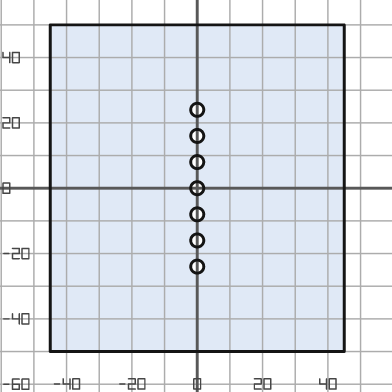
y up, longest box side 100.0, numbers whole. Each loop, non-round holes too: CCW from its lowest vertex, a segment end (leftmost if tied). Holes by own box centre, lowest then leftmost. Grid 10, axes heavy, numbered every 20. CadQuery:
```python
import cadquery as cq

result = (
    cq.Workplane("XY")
    .moveTo(-45.0, -50.0)
    .lineTo(45.0, -50.0)
    .lineTo(45.0, 50.0)
    .lineTo(-45.0, 50.0)
    .close()
    .moveTo(0.0, -24.0)
    .circle(2.0)
    .moveTo(0.0, -16.0)
    .circle(2.0)
    .moveTo(0.0, -8.0)
    .circle(2.0)
    .moveTo(0.0, 0.0)
    .circle(2.0)
    .moveTo(0.0, 8.0)
    .circle(2.0)
    .moveTo(0.0, 16.0)
    .circle(2.0)
    .moveTo(0.0, 24.0)
    .circle(2.0)
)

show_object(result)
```